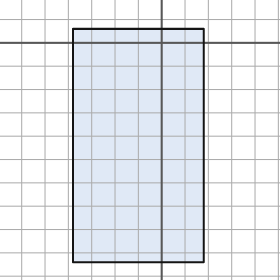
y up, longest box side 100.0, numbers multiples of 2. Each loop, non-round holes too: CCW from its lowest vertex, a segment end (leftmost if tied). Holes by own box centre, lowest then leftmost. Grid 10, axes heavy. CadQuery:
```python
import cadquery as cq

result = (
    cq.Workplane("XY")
    .moveTo(-38.0, -94.0)
    .lineTo(18.0, -94.0)
    .lineTo(18.0, 6.0)
    .lineTo(-38.0, 6.0)
    .close()
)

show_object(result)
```